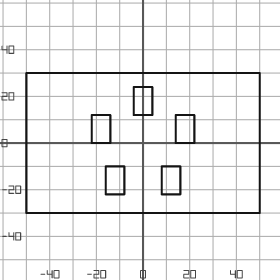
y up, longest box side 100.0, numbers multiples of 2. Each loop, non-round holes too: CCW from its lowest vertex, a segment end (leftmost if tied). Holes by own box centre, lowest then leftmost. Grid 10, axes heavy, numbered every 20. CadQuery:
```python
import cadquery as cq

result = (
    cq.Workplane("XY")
    .moveTo(-50.0, -30.0)
    .lineTo(50.0, -30.0)
    .lineTo(50.0, 30.0)
    .lineTo(-50.0, 30.0)
    .close()
    .moveTo(-16.0, -22.0)
    .lineTo(-8.0, -22.0)
    .lineTo(-8.0, -10.0)
    .lineTo(-16.0, -10.0)
    .close()
    .moveTo(8.0, -22.0)
    .lineTo(16.0, -22.0)
    .lineTo(16.0, -10.0)
    .lineTo(8.0, -10.0)
    .close()
    .moveTo(-22.0, 0.0)
    .lineTo(-14.0, 0.0)
    .lineTo(-14.0, 12.0)
    .lineTo(-22.0, 12.0)
    .close()
    .moveTo(14.0, 0.0)
    .lineTo(22.0, 0.0)
    .lineTo(22.0, 12.0)
    .lineTo(14.0, 12.0)
    .close()
    .moveTo(-4.0, 12.0)
    .lineTo(4.0, 12.0)
    .lineTo(4.0, 24.0)
    .lineTo(-4.0, 24.0)
    .close()
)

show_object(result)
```